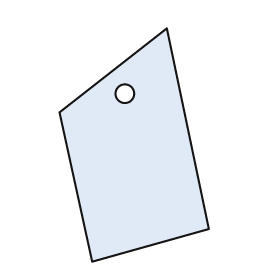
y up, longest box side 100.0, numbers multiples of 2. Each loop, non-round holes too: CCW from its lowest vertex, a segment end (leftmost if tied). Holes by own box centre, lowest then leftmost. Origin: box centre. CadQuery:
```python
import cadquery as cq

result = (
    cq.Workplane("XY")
    .moveTo(-18.0, -50.0)
    .lineTo(32.0, -36.0)
    .lineTo(14.0, 50.0)
    .lineTo(-32.0, 14.0)
    .close()
    .moveTo(-4.0, 22.0)
    .circle(4.0)
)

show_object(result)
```